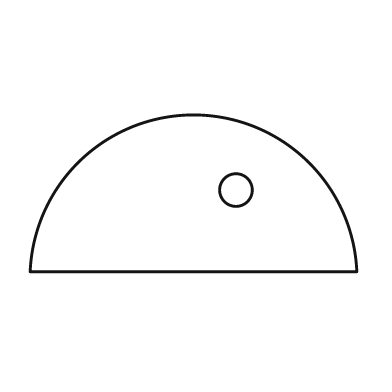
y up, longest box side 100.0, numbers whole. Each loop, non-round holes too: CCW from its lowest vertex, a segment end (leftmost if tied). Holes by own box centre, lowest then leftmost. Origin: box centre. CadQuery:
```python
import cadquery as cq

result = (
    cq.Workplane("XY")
    .moveTo(-50.0, -24.0)
    .lineTo(50.0, -24.0)
    .threePointArc((0.0, 24.0), (-50.0, -24.0))
    .close()
    .moveTo(13.0, 1.0)
    .circle(5.0)
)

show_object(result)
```